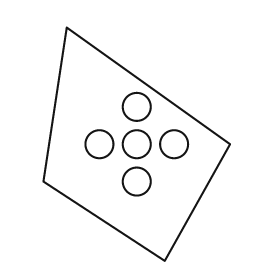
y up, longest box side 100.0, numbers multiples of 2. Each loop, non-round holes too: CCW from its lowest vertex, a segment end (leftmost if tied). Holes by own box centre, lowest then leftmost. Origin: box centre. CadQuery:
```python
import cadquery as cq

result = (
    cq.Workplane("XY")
    .moveTo(12.0, -50.0)
    .lineTo(40.0, 0.0)
    .lineTo(-30.0, 50.0)
    .lineTo(-40.0, -16.0)
    .close()
    .moveTo(0.0, -16.0)
    .circle(6.0)
    .moveTo(-16.0, 0.0)
    .circle(6.0)
    .moveTo(0.0, 0.0)
    .circle(6.0)
    .moveTo(16.0, 0.0)
    .circle(6.0)
    .moveTo(0.0, 16.0)
    .circle(6.0)
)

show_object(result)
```